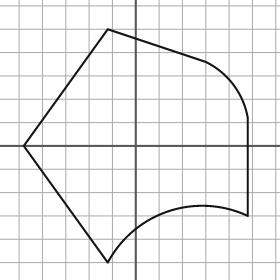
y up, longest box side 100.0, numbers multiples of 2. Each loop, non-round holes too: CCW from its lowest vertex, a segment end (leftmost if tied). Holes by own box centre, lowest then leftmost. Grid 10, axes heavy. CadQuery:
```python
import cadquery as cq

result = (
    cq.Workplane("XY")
    .moveTo(-12.0, -50.0)
    .threePointArc((14.0, -28.0), (48.0, -30.0))
    .lineTo(48.0, 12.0)
    .threePointArc((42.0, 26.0), (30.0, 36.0))
    .lineTo(-12.0, 50.0)
    .lineTo(-48.0, 0.0)
    .close()
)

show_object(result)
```